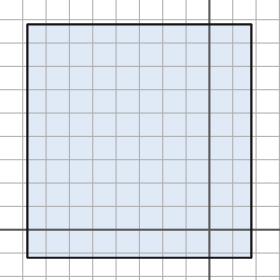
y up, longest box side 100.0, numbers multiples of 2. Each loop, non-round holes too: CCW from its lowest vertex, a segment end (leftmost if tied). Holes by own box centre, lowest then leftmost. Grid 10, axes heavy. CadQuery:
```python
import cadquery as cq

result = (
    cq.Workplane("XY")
    .moveTo(-78.0, -12.0)
    .lineTo(18.0, -12.0)
    .lineTo(18.0, 88.0)
    .lineTo(-78.0, 88.0)
    .close()
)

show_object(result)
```